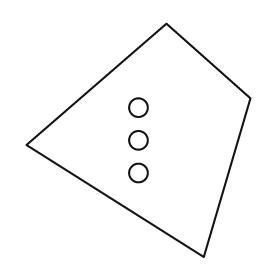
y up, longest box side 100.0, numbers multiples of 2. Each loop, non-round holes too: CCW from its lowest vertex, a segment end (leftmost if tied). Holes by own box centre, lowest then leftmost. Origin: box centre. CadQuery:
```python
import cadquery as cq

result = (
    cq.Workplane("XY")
    .moveTo(28.0, -50.0)
    .lineTo(48.0, 18.0)
    .lineTo(12.0, 50.0)
    .lineTo(-48.0, -2.0)
    .close()
    .moveTo(0.0, -14.0)
    .circle(4.0)
    .moveTo(0.0, 0.0)
    .circle(4.0)
    .moveTo(0.0, 14.0)
    .circle(4.0)
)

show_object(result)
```